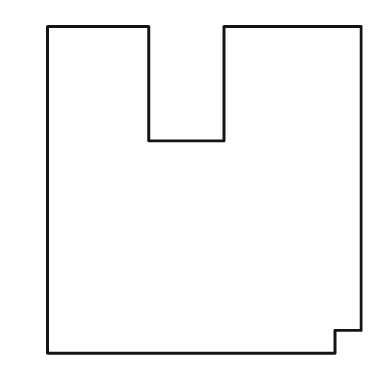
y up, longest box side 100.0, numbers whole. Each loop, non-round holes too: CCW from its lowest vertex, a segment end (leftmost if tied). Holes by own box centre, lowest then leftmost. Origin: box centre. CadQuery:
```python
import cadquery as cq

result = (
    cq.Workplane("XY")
    .moveTo(-48.0, -50.0)
    .lineTo(40.0, -50.0)
    .lineTo(40.0, -43.0)
    .lineTo(48.0, -43.0)
    .lineTo(48.0, 50.0)
    .lineTo(6.0, 50.0)
    .lineTo(6.0, 15.0)
    .lineTo(-17.0, 15.0)
    .lineTo(-17.0, 50.0)
    .lineTo(-48.0, 50.0)
    .close()
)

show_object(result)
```